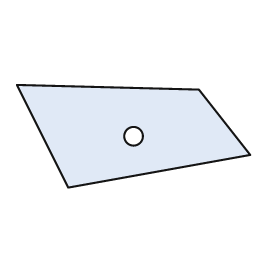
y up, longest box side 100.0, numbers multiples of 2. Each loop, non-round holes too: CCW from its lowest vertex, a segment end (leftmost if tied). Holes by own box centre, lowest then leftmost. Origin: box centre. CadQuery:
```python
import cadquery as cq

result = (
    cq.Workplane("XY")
    .moveTo(-28.0, -22.0)
    .lineTo(50.0, -8.0)
    .lineTo(28.0, 20.0)
    .lineTo(-50.0, 22.0)
    .close()
    .moveTo(0.0, 0.0)
    .circle(4.0)
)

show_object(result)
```